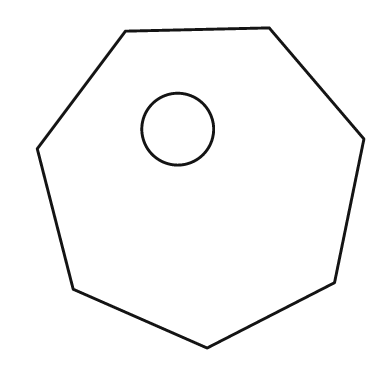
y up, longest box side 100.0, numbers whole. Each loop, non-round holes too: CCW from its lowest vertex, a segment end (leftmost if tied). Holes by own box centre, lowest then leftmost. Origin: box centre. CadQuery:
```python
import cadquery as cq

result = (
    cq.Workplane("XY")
    .moveTo(2.0, -49.0)
    .lineTo(41.0, -29.0)
    .lineTo(50.0, 15.0)
    .lineTo(21.0, 49.0)
    .lineTo(-23.0, 48.0)
    .lineTo(-50.0, 12.0)
    .lineTo(-39.0, -31.0)
    .close()
    .moveTo(-7.0, 18.0)
    .circle(11.0)
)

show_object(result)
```